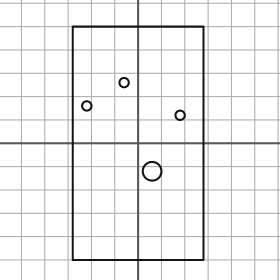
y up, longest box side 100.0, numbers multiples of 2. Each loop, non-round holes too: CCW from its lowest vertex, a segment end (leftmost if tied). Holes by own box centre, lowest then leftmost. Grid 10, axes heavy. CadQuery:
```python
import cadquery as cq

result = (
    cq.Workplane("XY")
    .moveTo(-28.0, -50.0)
    .lineTo(28.0, -50.0)
    .lineTo(28.0, 50.0)
    .lineTo(-28.0, 50.0)
    .close()
    .moveTo(6.0, -12.0)
    .circle(4.0)
    .moveTo(18.0, 12.0)
    .circle(2.0)
    .moveTo(-22.0, 16.0)
    .circle(2.0)
    .moveTo(-6.0, 26.0)
    .circle(2.0)
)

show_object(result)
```